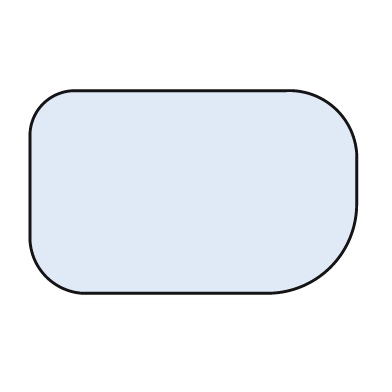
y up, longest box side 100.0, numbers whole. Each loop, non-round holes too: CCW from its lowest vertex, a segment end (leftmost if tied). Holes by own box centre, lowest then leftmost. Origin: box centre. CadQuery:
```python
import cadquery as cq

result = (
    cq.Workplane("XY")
    .moveTo(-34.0, -31.0)
    .lineTo(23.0, -31.0)
    .threePointArc((42.0, -23.0), (50.0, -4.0))
    .lineTo(50.0, 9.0)
    .threePointArc((44.0, 25.0), (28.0, 31.0))
    .lineTo(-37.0, 31.0)
    .threePointArc((-46.0, 27.0), (-50.0, 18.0))
    .lineTo(-50.0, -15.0)
    .threePointArc((-45.0, -26.0), (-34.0, -31.0))
    .close()
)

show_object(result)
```